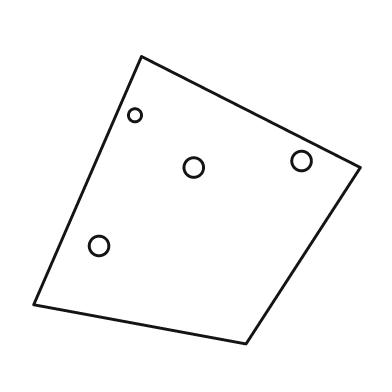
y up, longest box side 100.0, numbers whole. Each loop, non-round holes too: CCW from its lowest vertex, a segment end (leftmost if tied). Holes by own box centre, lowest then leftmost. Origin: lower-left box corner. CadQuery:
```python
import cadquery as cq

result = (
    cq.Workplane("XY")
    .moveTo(65.0, 0.0)
    .lineTo(100.0, 54.0)
    .lineTo(33.0, 88.0)
    .lineTo(0.0, 12.0)
    .close()
    .moveTo(20.0, 30.0)
    .circle(3.0)
    .moveTo(49.0, 54.0)
    .circle(3.0)
    .moveTo(82.0, 56.0)
    .circle(3.0)
    .moveTo(31.0, 70.0)
    .circle(2.0)
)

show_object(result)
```